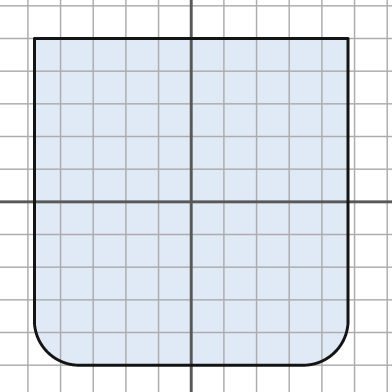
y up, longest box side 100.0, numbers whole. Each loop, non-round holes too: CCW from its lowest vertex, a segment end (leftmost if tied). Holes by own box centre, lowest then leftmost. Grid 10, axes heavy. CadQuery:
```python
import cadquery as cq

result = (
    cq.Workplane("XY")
    .moveTo(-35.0, -50.0)
    .lineTo(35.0, -50.0)
    .threePointArc((44.0, -46.0), (48.0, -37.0))
    .lineTo(48.0, 50.0)
    .lineTo(-48.0, 50.0)
    .lineTo(-48.0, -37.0)
    .threePointArc((-44.0, -46.0), (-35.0, -50.0))
    .close()
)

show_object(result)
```